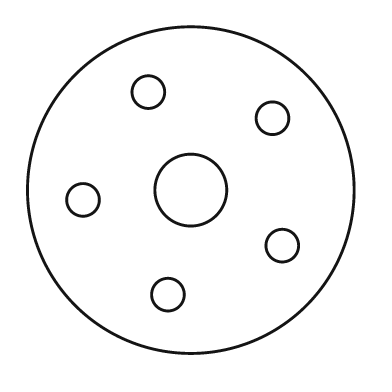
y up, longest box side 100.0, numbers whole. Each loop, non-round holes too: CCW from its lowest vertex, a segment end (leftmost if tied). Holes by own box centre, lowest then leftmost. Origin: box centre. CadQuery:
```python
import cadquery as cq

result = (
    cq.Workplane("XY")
    .moveTo(0.0, 0.0)
    .circle(50.0)
    .moveTo(-7.0, -32.0)
    .circle(5.0)
    .moveTo(28.0, -17.0)
    .circle(5.0)
    .moveTo(-33.0, -3.0)
    .circle(5.0)
    .moveTo(0.0, 0.0)
    .circle(11.0)
    .moveTo(25.0, 22.0)
    .circle(5.0)
    .moveTo(-13.0, 30.0)
    .circle(5.0)
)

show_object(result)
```